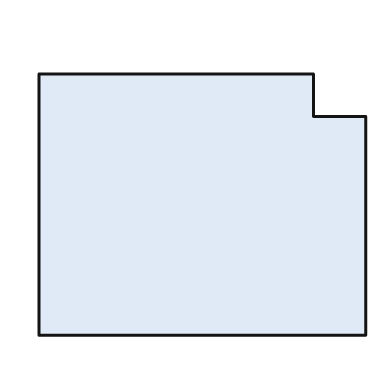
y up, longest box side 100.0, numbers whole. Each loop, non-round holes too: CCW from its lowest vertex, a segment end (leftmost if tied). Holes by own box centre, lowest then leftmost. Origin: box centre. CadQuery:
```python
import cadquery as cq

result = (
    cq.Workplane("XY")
    .moveTo(-50.0, -40.0)
    .lineTo(50.0, -40.0)
    .lineTo(50.0, 27.0)
    .lineTo(34.0, 27.0)
    .lineTo(34.0, 40.0)
    .lineTo(-50.0, 40.0)
    .close()
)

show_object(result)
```